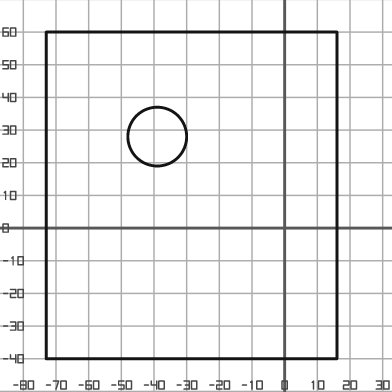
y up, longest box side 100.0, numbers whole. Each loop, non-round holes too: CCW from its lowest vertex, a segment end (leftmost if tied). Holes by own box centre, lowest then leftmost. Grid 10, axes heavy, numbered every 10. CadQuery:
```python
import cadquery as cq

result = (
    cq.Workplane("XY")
    .moveTo(-73.0, -40.0)
    .lineTo(16.0, -40.0)
    .lineTo(16.0, 60.0)
    .lineTo(-73.0, 60.0)
    .close()
    .moveTo(-39.0, 28.0)
    .circle(9.0)
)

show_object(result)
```